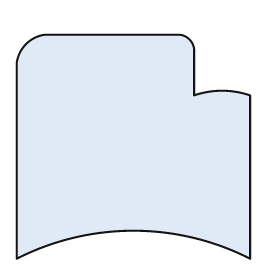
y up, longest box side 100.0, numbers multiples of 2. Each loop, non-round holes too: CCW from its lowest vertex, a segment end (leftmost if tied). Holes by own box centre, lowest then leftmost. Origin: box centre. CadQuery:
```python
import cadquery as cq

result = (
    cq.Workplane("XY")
    .moveTo(-50.0, -48.0)
    .threePointArc((0.0, -36.0), (50.0, -48.0))
    .lineTo(50.0, 22.0)
    .threePointArc((38.0, 24.0), (26.0, 22.0))
    .lineTo(26.0, 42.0)
    .threePointArc((24.0, 46.0), (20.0, 48.0))
    .lineTo(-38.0, 48.0)
    .threePointArc((-46.0, 44.0), (-50.0, 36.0))
    .close()
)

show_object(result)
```